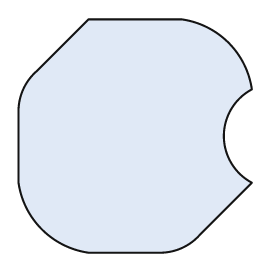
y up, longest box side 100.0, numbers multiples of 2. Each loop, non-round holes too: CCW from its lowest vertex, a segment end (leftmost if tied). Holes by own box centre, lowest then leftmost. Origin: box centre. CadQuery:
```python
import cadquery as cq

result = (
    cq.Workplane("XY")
    .moveTo(-20.0, -50.0)
    .lineTo(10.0, -50.0)
    .threePointArc((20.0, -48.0), (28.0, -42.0))
    .lineTo(50.0, -20.0)
    .threePointArc((38.0, 0.0), (50.0, 20.0))
    .threePointArc((40.0, 40.0), (20.0, 50.0))
    .lineTo(-20.0, 50.0)
    .lineTo(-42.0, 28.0)
    .threePointArc((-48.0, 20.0), (-50.0, 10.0))
    .lineTo(-50.0, -20.0)
    .threePointArc((-40.0, -40.0), (-20.0, -50.0))
    .close()
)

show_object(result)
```